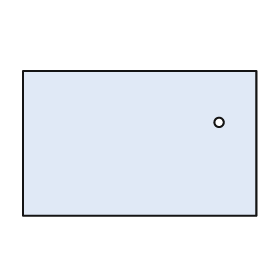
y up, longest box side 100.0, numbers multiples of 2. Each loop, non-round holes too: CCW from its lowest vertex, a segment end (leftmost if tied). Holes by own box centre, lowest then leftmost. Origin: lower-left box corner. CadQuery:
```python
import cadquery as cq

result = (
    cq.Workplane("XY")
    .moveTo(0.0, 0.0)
    .lineTo(100.0, 0.0)
    .lineTo(100.0, 62.0)
    .lineTo(0.0, 62.0)
    .close()
    .moveTo(84.0, 40.0)
    .circle(2.0)
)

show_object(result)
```